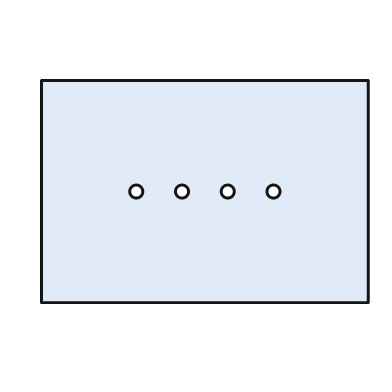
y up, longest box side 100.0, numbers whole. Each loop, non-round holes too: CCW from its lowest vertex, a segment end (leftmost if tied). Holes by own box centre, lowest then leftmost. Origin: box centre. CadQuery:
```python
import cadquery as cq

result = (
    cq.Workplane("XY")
    .moveTo(-50.0, -34.0)
    .lineTo(50.0, -34.0)
    .lineTo(50.0, 34.0)
    .lineTo(-50.0, 34.0)
    .close()
    .moveTo(-21.0, 0.0)
    .circle(2.0)
    .moveTo(-7.0, 0.0)
    .circle(2.0)
    .moveTo(7.0, 0.0)
    .circle(2.0)
    .moveTo(21.0, 0.0)
    .circle(2.0)
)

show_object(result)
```